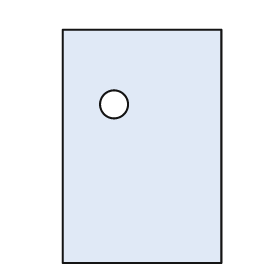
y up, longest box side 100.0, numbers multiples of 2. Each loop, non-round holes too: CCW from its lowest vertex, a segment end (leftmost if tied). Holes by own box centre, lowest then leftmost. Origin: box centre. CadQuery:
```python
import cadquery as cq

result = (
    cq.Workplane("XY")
    .moveTo(-34.0, -50.0)
    .lineTo(34.0, -50.0)
    .lineTo(34.0, 50.0)
    .lineTo(-34.0, 50.0)
    .close()
    .moveTo(-12.0, 18.0)
    .circle(6.0)
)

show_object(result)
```